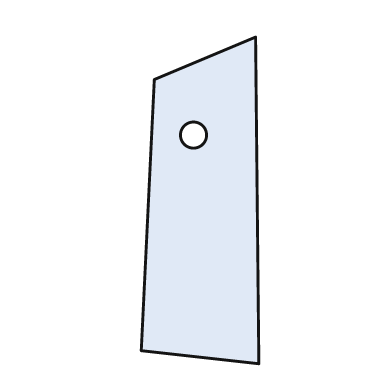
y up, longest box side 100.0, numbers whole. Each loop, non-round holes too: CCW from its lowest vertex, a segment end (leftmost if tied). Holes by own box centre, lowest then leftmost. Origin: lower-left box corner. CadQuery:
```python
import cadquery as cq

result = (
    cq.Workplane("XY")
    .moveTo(36.0, 0.0)
    .lineTo(35.0, 100.0)
    .lineTo(4.0, 87.0)
    .lineTo(0.0, 4.0)
    .close()
    .moveTo(16.0, 70.0)
    .circle(4.0)
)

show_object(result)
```